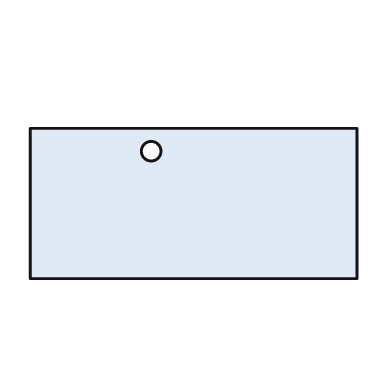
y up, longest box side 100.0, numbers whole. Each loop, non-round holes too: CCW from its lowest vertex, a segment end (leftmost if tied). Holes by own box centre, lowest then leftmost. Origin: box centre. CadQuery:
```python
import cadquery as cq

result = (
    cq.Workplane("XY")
    .moveTo(-50.0, -23.0)
    .lineTo(50.0, -23.0)
    .lineTo(50.0, 23.0)
    .lineTo(-50.0, 23.0)
    .close()
    .moveTo(-13.0, 16.0)
    .circle(3.0)
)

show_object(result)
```